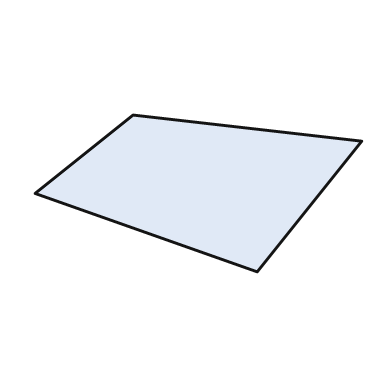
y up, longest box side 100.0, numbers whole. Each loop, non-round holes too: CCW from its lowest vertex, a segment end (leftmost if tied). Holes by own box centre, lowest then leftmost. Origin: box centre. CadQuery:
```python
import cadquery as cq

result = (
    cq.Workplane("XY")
    .moveTo(18.0, -24.0)
    .lineTo(50.0, 16.0)
    .lineTo(-20.0, 24.0)
    .lineTo(-50.0, 0.0)
    .close()
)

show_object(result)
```